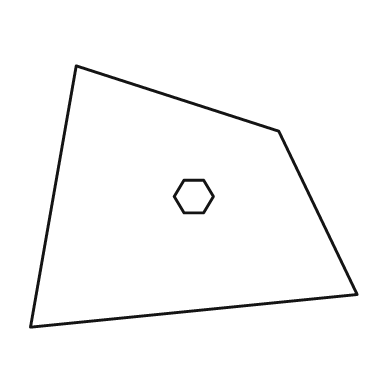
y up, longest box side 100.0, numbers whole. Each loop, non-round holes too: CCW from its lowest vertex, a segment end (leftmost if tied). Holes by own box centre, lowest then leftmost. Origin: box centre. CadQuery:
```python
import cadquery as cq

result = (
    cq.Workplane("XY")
    .moveTo(-50.0, -40.0)
    .lineTo(50.0, -30.0)
    .lineTo(26.0, 20.0)
    .lineTo(-36.0, 40.0)
    .close()
    .moveTo(-3.0, -5.0)
    .lineTo(3.0, -5.0)
    .lineTo(6.0, 0.0)
    .lineTo(3.0, 5.0)
    .lineTo(-3.0, 5.0)
    .lineTo(-6.0, 0.0)
    .close()
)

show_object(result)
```